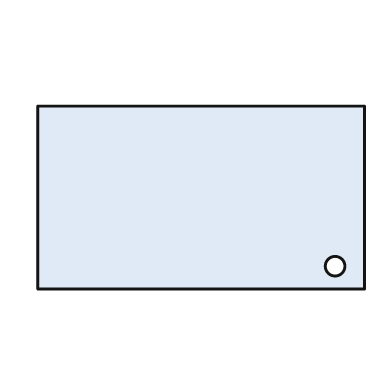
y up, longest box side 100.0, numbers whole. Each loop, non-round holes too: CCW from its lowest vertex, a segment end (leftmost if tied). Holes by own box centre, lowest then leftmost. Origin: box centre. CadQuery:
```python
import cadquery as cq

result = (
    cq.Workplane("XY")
    .moveTo(-50.0, -28.0)
    .lineTo(50.0, -28.0)
    .lineTo(50.0, 28.0)
    .lineTo(-50.0, 28.0)
    .close()
    .moveTo(41.0, -21.0)
    .circle(3.0)
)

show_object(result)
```